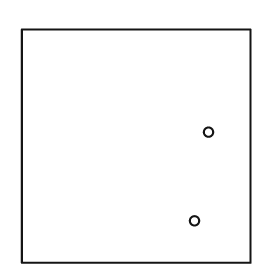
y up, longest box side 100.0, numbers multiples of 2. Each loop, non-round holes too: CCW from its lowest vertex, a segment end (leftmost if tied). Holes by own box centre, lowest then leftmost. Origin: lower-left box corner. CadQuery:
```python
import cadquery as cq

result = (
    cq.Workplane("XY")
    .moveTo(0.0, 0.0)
    .lineTo(98.0, 0.0)
    .lineTo(98.0, 100.0)
    .lineTo(0.0, 100.0)
    .close()
    .moveTo(74.0, 18.0)
    .circle(2.0)
    .moveTo(80.0, 56.0)
    .circle(2.0)
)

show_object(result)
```